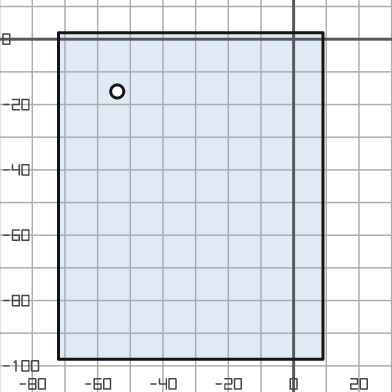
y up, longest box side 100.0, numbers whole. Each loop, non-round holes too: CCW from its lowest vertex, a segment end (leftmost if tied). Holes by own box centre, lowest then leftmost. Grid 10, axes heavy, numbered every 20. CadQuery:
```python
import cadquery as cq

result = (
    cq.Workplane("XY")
    .moveTo(-72.0, -98.0)
    .lineTo(9.0, -98.0)
    .lineTo(9.0, 2.0)
    .lineTo(-72.0, 2.0)
    .close()
    .moveTo(-54.0, -16.0)
    .circle(2.0)
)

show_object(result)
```